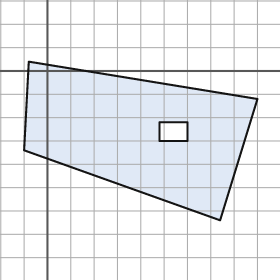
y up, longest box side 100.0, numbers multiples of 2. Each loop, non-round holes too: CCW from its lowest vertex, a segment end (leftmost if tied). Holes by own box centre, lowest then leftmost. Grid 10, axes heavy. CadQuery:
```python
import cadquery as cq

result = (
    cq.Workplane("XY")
    .moveTo(74.0, -64.0)
    .lineTo(90.0, -12.0)
    .lineTo(-8.0, 4.0)
    .lineTo(-10.0, -34.0)
    .close()
    .moveTo(48.0, -30.0)
    .lineTo(60.0, -30.0)
    .lineTo(60.0, -22.0)
    .lineTo(48.0, -22.0)
    .close()
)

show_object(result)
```